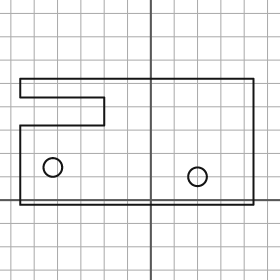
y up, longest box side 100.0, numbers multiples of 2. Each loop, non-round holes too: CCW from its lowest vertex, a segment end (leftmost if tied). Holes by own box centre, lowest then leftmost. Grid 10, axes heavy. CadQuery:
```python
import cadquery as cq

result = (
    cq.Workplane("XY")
    .moveTo(-56.0, -2.0)
    .lineTo(44.0, -2.0)
    .lineTo(44.0, 52.0)
    .lineTo(-56.0, 52.0)
    .lineTo(-56.0, 44.0)
    .lineTo(-20.0, 44.0)
    .lineTo(-20.0, 32.0)
    .lineTo(-56.0, 32.0)
    .close()
    .moveTo(20.0, 10.0)
    .circle(4.0)
    .moveTo(-42.0, 14.0)
    .circle(4.0)
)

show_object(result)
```